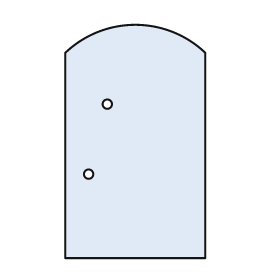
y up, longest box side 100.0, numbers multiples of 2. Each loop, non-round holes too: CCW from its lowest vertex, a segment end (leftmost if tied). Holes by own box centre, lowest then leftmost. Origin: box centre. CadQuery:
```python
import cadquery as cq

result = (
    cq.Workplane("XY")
    .moveTo(-30.0, -50.0)
    .lineTo(30.0, -50.0)
    .lineTo(30.0, 38.0)
    .threePointArc((0.0, 50.0), (-30.0, 38.0))
    .close()
    .moveTo(-20.0, -14.0)
    .circle(2.0)
    .moveTo(-12.0, 16.0)
    .circle(2.0)
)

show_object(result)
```